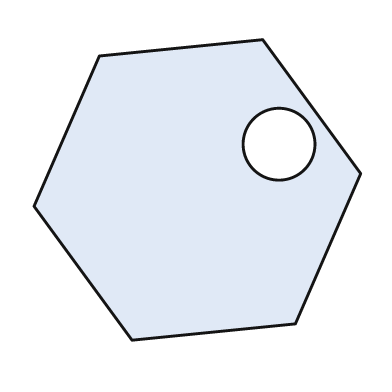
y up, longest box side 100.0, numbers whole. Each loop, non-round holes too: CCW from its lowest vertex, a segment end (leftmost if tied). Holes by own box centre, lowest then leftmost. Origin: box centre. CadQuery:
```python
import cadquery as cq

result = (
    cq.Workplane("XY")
    .moveTo(-20.0, -46.0)
    .lineTo(30.0, -41.0)
    .lineTo(50.0, 5.0)
    .lineTo(20.0, 46.0)
    .lineTo(-30.0, 41.0)
    .lineTo(-50.0, -5.0)
    .close()
    .moveTo(25.0, 14.0)
    .circle(11.0)
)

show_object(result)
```